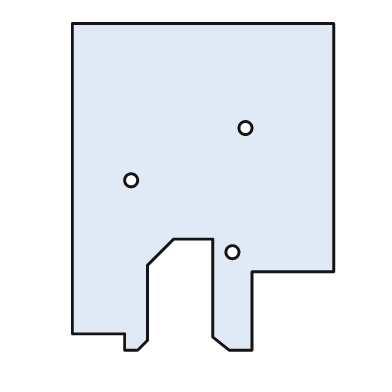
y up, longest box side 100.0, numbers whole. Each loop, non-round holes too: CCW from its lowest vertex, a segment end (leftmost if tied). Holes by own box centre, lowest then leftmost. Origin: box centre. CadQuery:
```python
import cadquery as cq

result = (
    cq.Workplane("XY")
    .moveTo(-24.0, -50.0)
    .lineTo(-20.0, -50.0)
    .lineTo(-17.0, -47.0)
    .lineTo(-17.0, -24.0)
    .lineTo(-9.0, -16.0)
    .lineTo(3.0, -16.0)
    .lineTo(3.0, -46.0)
    .lineTo(8.0, -50.0)
    .lineTo(15.0, -50.0)
    .lineTo(15.0, -26.0)
    .lineTo(40.0, -26.0)
    .lineTo(40.0, 50.0)
    .lineTo(-40.0, 50.0)
    .lineTo(-40.0, -45.0)
    .lineTo(-24.0, -45.0)
    .close()
    .moveTo(9.0, -20.0)
    .circle(2.0)
    .moveTo(-22.0, 2.0)
    .circle(2.0)
    .moveTo(13.0, 18.0)
    .circle(2.0)
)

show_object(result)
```